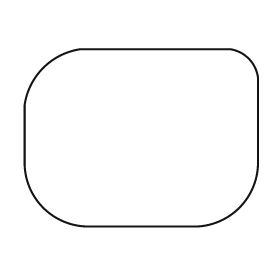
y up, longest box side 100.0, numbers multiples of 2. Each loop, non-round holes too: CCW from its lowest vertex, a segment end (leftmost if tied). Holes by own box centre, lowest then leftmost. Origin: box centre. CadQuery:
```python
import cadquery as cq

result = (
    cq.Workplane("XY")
    .moveTo(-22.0, -38.0)
    .lineTo(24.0, -38.0)
    .threePointArc((42.0, -30.0), (50.0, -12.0))
    .lineTo(50.0, 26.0)
    .threePointArc((46.0, 34.0), (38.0, 38.0))
    .lineTo(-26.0, 38.0)
    .threePointArc((-42.0, 30.0), (-50.0, 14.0))
    .lineTo(-50.0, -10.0)
    .threePointArc((-42.0, -30.0), (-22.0, -38.0))
    .close()
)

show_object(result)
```